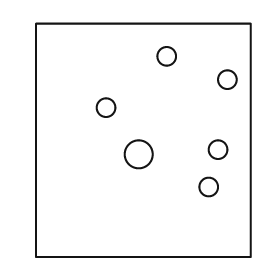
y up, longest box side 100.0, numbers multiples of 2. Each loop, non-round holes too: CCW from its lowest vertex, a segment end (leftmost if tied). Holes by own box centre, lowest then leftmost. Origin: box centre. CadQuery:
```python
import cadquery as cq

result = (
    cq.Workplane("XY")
    .moveTo(-46.0, -50.0)
    .lineTo(46.0, -50.0)
    .lineTo(46.0, 50.0)
    .lineTo(-46.0, 50.0)
    .close()
    .moveTo(28.0, -20.0)
    .circle(4.0)
    .moveTo(-2.0, -6.0)
    .circle(6.0)
    .moveTo(32.0, -4.0)
    .circle(4.0)
    .moveTo(-16.0, 14.0)
    .circle(4.0)
    .moveTo(36.0, 26.0)
    .circle(4.0)
    .moveTo(10.0, 36.0)
    .circle(4.0)
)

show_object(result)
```